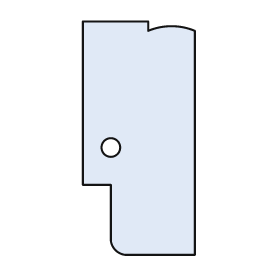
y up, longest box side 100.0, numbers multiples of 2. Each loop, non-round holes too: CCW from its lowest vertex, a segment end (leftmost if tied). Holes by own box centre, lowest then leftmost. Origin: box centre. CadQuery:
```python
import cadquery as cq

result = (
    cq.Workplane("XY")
    .moveTo(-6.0, -50.0)
    .lineTo(24.0, -50.0)
    .lineTo(24.0, 46.0)
    .threePointArc((14.0, 48.0), (4.0, 46.0))
    .lineTo(4.0, 50.0)
    .lineTo(-24.0, 50.0)
    .lineTo(-24.0, -20.0)
    .lineTo(-12.0, -20.0)
    .lineTo(-12.0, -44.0)
    .threePointArc((-10.0, -48.0), (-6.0, -50.0))
    .close()
    .moveTo(-12.0, -4.0)
    .circle(4.0)
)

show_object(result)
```